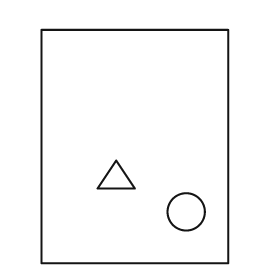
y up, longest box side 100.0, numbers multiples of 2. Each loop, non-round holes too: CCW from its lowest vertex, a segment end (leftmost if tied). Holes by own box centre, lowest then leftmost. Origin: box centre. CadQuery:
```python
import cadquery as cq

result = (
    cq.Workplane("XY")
    .moveTo(-40.0, -50.0)
    .lineTo(40.0, -50.0)
    .lineTo(40.0, 50.0)
    .lineTo(-40.0, 50.0)
    .close()
    .moveTo(22.0, -28.0)
    .circle(8.0)
    .moveTo(-16.0, -18.0)
    .lineTo(0.0, -18.0)
    .lineTo(-8.0, -6.0)
    .close()
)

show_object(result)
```